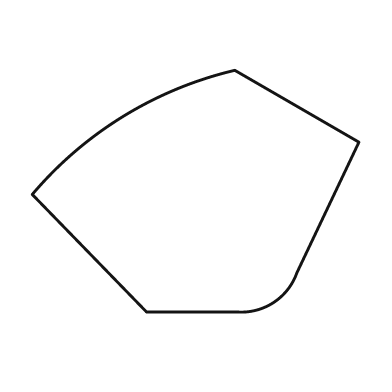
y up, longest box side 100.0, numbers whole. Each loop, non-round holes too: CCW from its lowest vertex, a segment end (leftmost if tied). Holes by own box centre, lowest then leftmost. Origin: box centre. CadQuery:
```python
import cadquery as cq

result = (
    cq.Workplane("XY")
    .moveTo(-15.0, -37.0)
    .lineTo(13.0, -37.0)
    .threePointArc((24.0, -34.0), (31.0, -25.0))
    .lineTo(50.0, 15.0)
    .lineTo(12.0, 37.0)
    .threePointArc((-22.0, 23.0), (-50.0, -1.0))
    .close()
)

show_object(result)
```